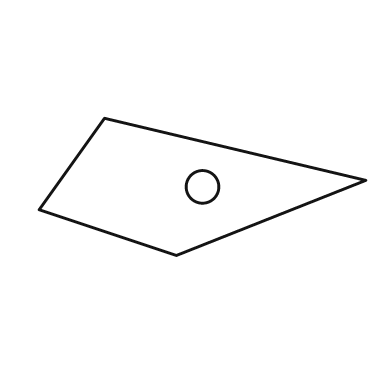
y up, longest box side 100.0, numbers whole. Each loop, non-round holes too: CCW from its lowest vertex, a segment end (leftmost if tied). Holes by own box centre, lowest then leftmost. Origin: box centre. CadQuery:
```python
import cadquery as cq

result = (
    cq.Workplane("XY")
    .moveTo(-8.0, -21.0)
    .lineTo(50.0, 2.0)
    .lineTo(-30.0, 21.0)
    .lineTo(-50.0, -7.0)
    .close()
    .moveTo(0.0, 0.0)
    .circle(5.0)
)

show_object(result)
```